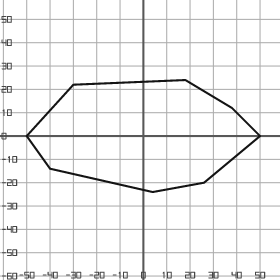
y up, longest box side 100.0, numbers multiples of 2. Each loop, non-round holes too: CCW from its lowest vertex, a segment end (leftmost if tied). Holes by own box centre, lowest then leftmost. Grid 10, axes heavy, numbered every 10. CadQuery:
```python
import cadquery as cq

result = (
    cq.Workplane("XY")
    .moveTo(4.0, -24.0)
    .lineTo(26.0, -20.0)
    .lineTo(50.0, 0.0)
    .lineTo(38.0, 12.0)
    .lineTo(18.0, 24.0)
    .lineTo(-30.0, 22.0)
    .lineTo(-50.0, 0.0)
    .lineTo(-40.0, -14.0)
    .close()
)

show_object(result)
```